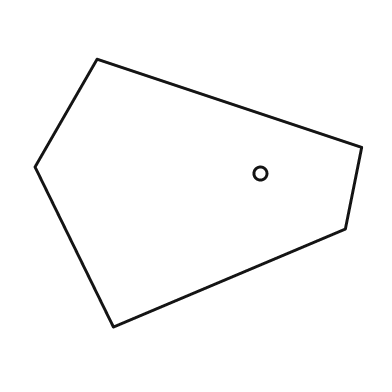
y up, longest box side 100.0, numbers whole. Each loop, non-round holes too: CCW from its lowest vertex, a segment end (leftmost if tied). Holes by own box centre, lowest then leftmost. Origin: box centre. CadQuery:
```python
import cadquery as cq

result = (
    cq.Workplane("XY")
    .moveTo(-26.0, -41.0)
    .lineTo(45.0, -11.0)
    .lineTo(50.0, 14.0)
    .lineTo(-31.0, 41.0)
    .lineTo(-50.0, 8.0)
    .close()
    .moveTo(19.0, 6.0)
    .circle(2.0)
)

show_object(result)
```